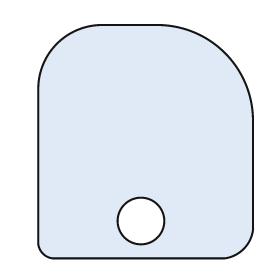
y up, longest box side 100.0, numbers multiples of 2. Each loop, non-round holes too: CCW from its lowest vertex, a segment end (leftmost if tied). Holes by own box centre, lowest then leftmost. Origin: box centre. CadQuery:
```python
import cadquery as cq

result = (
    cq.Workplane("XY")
    .moveTo(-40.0, -50.0)
    .lineTo(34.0, -50.0)
    .threePointArc((42.0, -46.0), (46.0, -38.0))
    .lineTo(46.0, 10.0)
    .threePointArc((34.0, 38.0), (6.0, 50.0))
    .lineTo(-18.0, 50.0)
    .threePointArc((-38.0, 42.0), (-46.0, 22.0))
    .lineTo(-46.0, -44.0)
    .threePointArc((-44.0, -48.0), (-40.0, -50.0))
    .close()
    .moveTo(-2.0, -34.0)
    .circle(10.0)
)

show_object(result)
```